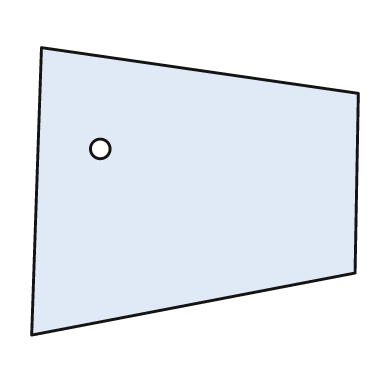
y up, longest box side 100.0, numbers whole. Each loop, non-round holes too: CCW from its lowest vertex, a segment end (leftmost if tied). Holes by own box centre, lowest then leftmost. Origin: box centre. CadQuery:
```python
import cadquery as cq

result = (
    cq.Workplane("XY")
    .moveTo(-50.0, -44.0)
    .lineTo(49.0, -25.0)
    .lineTo(50.0, 30.0)
    .lineTo(-47.0, 44.0)
    .close()
    .moveTo(-29.0, 13.0)
    .circle(3.0)
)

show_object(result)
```